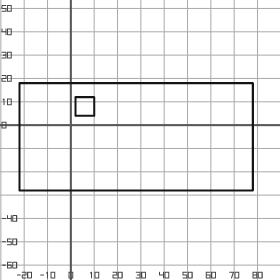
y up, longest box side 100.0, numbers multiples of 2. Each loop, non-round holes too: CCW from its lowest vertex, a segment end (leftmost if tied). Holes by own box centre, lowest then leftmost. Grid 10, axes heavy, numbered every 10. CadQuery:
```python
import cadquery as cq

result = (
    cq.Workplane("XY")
    .moveTo(-22.0, -28.0)
    .lineTo(78.0, -28.0)
    .lineTo(78.0, 18.0)
    .lineTo(-22.0, 18.0)
    .close()
    .moveTo(2.0, 4.0)
    .lineTo(10.0, 4.0)
    .lineTo(10.0, 12.0)
    .lineTo(2.0, 12.0)
    .close()
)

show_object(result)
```